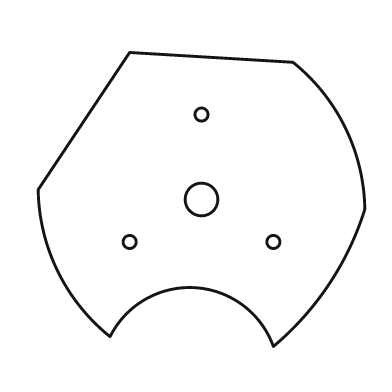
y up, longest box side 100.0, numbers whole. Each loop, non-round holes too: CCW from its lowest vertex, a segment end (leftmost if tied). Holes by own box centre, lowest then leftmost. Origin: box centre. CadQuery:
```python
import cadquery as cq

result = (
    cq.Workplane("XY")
    .moveTo(22.0, -45.0)
    .threePointArc((39.0, -26.0), (50.0, -3.0))
    .threePointArc((44.0, 22.0), (28.0, 42.0))
    .lineTo(-22.0, 45.0)
    .lineTo(-50.0, 3.0)
    .threePointArc((-44.0, -22.0), (-28.0, -42.0))
    .threePointArc((-2.0, -27.0), (22.0, -45.0))
    .close()
    .moveTo(-22.0, -13.0)
    .circle(2.0)
    .moveTo(22.0, -13.0)
    .circle(2.0)
    .moveTo(0.0, 0.0)
    .circle(5.0)
    .moveTo(0.0, 26.0)
    .circle(2.0)
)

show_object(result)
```